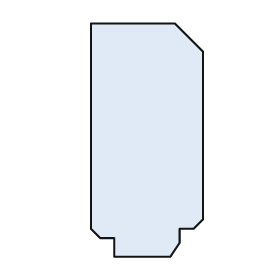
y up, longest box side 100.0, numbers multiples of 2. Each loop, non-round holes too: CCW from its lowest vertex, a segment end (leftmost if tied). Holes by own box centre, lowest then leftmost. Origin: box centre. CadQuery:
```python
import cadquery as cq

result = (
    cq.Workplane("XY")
    .moveTo(-14.0, -50.0)
    .lineTo(10.0, -50.0)
    .lineTo(14.0, -44.0)
    .lineTo(14.0, -38.0)
    .lineTo(20.0, -38.0)
    .lineTo(24.0, -34.0)
    .lineTo(24.0, 38.0)
    .lineTo(12.0, 50.0)
    .lineTo(-24.0, 50.0)
    .lineTo(-24.0, -38.0)
    .lineTo(-20.0, -42.0)
    .lineTo(-14.0, -42.0)
    .close()
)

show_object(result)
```